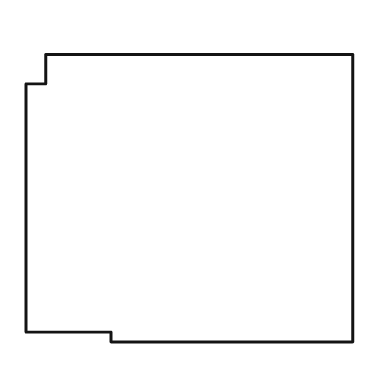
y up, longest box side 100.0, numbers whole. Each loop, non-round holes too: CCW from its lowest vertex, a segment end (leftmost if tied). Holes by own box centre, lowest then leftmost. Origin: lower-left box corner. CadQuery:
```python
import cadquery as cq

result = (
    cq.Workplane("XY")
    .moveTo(26.0, 0.0)
    .lineTo(100.0, 0.0)
    .lineTo(100.0, 88.0)
    .lineTo(6.0, 88.0)
    .lineTo(6.0, 79.0)
    .lineTo(0.0, 79.0)
    .lineTo(0.0, 3.0)
    .lineTo(26.0, 3.0)
    .close()
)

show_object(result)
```